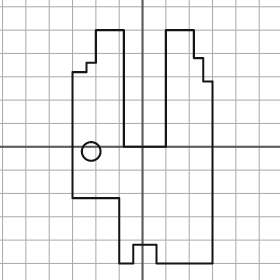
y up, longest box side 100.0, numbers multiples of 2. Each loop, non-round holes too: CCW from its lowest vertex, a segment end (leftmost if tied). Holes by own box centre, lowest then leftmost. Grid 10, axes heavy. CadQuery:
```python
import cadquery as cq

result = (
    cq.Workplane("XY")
    .moveTo(-10.0, -50.0)
    .lineTo(-4.0, -50.0)
    .lineTo(-4.0, -42.0)
    .lineTo(6.0, -42.0)
    .lineTo(6.0, -50.0)
    .lineTo(30.0, -50.0)
    .lineTo(30.0, 28.0)
    .lineTo(26.0, 28.0)
    .lineTo(26.0, 38.0)
    .lineTo(22.0, 38.0)
    .lineTo(22.0, 50.0)
    .lineTo(10.0, 50.0)
    .lineTo(10.0, 0.0)
    .lineTo(-8.0, 0.0)
    .lineTo(-8.0, 50.0)
    .lineTo(-20.0, 50.0)
    .lineTo(-20.0, 36.0)
    .lineTo(-24.0, 36.0)
    .lineTo(-24.0, 32.0)
    .lineTo(-30.0, 32.0)
    .lineTo(-30.0, -22.0)
    .lineTo(-10.0, -22.0)
    .close()
    .moveTo(-22.0, -2.0)
    .circle(4.0)
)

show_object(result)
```